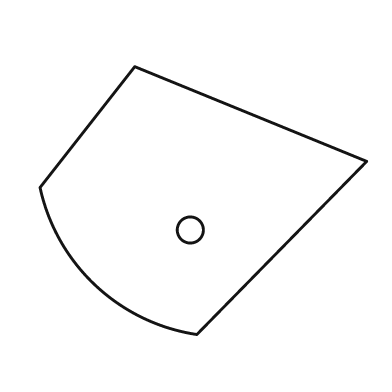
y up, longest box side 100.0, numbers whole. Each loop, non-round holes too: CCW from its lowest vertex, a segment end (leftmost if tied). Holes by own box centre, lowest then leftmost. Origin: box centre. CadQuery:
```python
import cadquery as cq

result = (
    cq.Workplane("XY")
    .moveTo(-2.0, -41.0)
    .lineTo(50.0, 12.0)
    .lineTo(-21.0, 41.0)
    .lineTo(-50.0, 4.0)
    .threePointArc((-33.0, -26.0), (-2.0, -41.0))
    .close()
    .moveTo(-4.0, -9.0)
    .circle(4.0)
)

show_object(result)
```